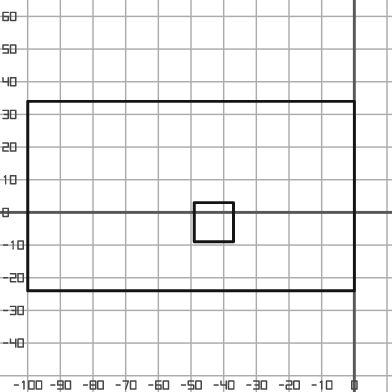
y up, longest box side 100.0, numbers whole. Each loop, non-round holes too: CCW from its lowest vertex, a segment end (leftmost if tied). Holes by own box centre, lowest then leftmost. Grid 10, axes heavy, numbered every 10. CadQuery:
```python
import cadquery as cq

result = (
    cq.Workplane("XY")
    .moveTo(-100.0, -24.0)
    .lineTo(0.0, -24.0)
    .lineTo(0.0, 34.0)
    .lineTo(-100.0, 34.0)
    .close()
    .moveTo(-49.0, -9.0)
    .lineTo(-37.0, -9.0)
    .lineTo(-37.0, 3.0)
    .lineTo(-49.0, 3.0)
    .close()
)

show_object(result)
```